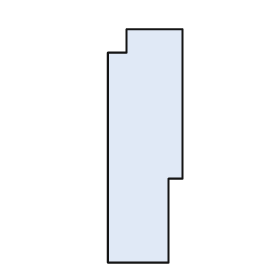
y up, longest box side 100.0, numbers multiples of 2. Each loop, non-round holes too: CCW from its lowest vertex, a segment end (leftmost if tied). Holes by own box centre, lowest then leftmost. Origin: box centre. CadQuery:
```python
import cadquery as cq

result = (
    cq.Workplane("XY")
    .moveTo(-16.0, -50.0)
    .lineTo(10.0, -50.0)
    .lineTo(10.0, -14.0)
    .lineTo(16.0, -14.0)
    .lineTo(16.0, 50.0)
    .lineTo(-8.0, 50.0)
    .lineTo(-8.0, 40.0)
    .lineTo(-16.0, 40.0)
    .close()
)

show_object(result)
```